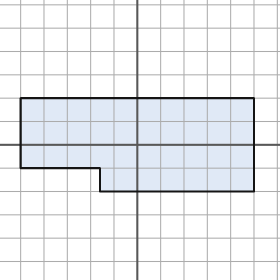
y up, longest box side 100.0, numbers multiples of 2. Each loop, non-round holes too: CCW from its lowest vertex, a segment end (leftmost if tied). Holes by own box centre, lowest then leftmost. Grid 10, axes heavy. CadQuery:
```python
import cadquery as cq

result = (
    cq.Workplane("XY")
    .moveTo(-16.0, -20.0)
    .lineTo(50.0, -20.0)
    .lineTo(50.0, 20.0)
    .lineTo(-50.0, 20.0)
    .lineTo(-50.0, -10.0)
    .lineTo(-16.0, -10.0)
    .close()
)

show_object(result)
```